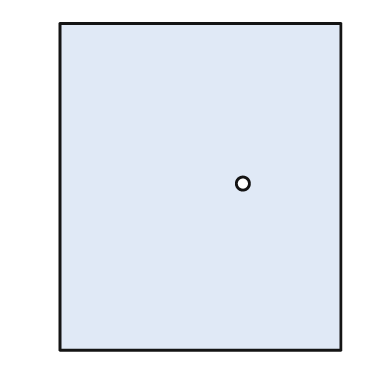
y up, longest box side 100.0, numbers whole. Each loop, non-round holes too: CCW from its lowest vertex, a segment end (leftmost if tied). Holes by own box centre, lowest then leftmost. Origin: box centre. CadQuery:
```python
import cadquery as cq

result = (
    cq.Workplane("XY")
    .moveTo(-43.0, -50.0)
    .lineTo(43.0, -50.0)
    .lineTo(43.0, 50.0)
    .lineTo(-43.0, 50.0)
    .close()
    .moveTo(13.0, 1.0)
    .circle(2.0)
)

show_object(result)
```